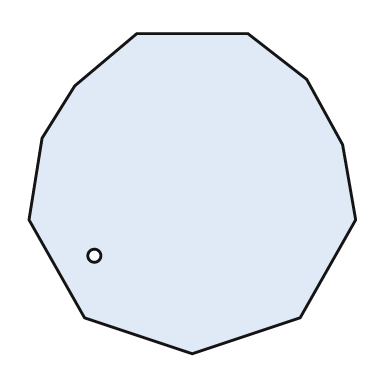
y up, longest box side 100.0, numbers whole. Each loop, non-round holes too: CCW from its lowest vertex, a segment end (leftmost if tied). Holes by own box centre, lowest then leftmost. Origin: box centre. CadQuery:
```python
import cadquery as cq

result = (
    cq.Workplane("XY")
    .moveTo(0.0, -49.0)
    .lineTo(33.0, -38.0)
    .lineTo(50.0, -8.0)
    .lineTo(46.0, 15.0)
    .lineTo(35.0, 35.0)
    .lineTo(17.0, 49.0)
    .lineTo(-17.0, 49.0)
    .lineTo(-36.0, 33.0)
    .lineTo(-46.0, 17.0)
    .lineTo(-50.0, -8.0)
    .lineTo(-33.0, -38.0)
    .close()
    .moveTo(-30.0, -19.0)
    .circle(2.0)
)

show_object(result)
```